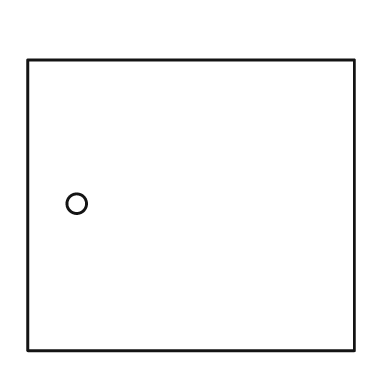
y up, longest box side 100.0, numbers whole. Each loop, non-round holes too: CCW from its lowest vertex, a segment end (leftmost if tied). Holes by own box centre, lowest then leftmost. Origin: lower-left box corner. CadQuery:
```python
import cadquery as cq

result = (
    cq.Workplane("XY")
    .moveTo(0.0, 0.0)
    .lineTo(100.0, 0.0)
    .lineTo(100.0, 89.0)
    .lineTo(0.0, 89.0)
    .close()
    .moveTo(15.0, 45.0)
    .circle(3.0)
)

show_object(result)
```